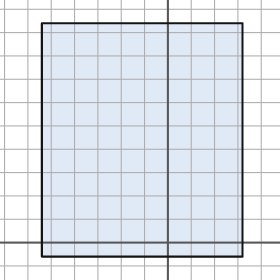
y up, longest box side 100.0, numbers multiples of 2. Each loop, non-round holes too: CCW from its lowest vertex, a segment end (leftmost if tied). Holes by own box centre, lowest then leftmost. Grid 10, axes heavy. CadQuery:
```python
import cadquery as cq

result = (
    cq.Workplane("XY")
    .moveTo(-54.0, -6.0)
    .lineTo(32.0, -6.0)
    .lineTo(32.0, 94.0)
    .lineTo(-54.0, 94.0)
    .close()
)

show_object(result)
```